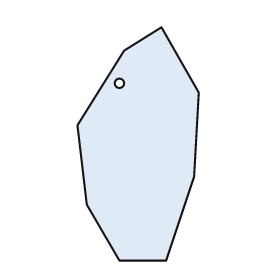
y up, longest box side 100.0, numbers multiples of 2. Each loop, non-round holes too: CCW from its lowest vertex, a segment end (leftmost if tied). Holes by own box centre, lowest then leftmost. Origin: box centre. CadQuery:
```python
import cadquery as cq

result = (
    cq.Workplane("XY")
    .moveTo(-8.0, -50.0)
    .lineTo(12.0, -50.0)
    .lineTo(24.0, -14.0)
    .lineTo(26.0, 22.0)
    .lineTo(10.0, 50.0)
    .lineTo(-6.0, 40.0)
    .lineTo(-26.0, 8.0)
    .lineTo(-22.0, -26.0)
    .close()
    .moveTo(-8.0, 26.0)
    .circle(2.0)
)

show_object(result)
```